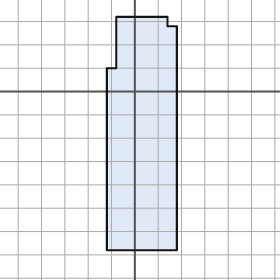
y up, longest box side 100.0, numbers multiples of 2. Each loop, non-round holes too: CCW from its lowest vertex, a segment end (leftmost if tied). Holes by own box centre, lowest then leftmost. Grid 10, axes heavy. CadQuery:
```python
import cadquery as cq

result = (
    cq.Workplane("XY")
    .moveTo(-12.0, -68.0)
    .lineTo(18.0, -68.0)
    .lineTo(18.0, 28.0)
    .lineTo(14.0, 28.0)
    .lineTo(14.0, 32.0)
    .lineTo(-8.0, 32.0)
    .lineTo(-8.0, 10.0)
    .lineTo(-12.0, 10.0)
    .close()
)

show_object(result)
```